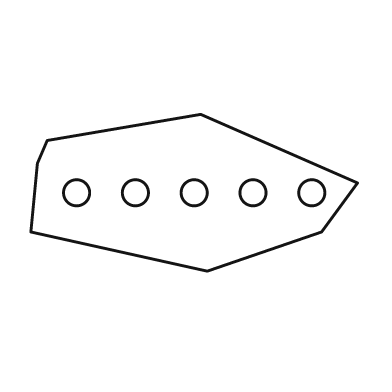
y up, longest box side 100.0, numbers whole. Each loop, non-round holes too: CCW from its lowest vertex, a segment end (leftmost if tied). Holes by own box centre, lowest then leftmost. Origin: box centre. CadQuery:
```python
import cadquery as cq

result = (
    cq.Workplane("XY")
    .moveTo(4.0, -24.0)
    .lineTo(39.0, -12.0)
    .lineTo(50.0, 3.0)
    .lineTo(2.0, 24.0)
    .lineTo(-45.0, 16.0)
    .lineTo(-48.0, 9.0)
    .lineTo(-50.0, -12.0)
    .close()
    .moveTo(-36.0, 0.0)
    .circle(4.0)
    .moveTo(-18.0, 0.0)
    .circle(4.0)
    .moveTo(0.0, 0.0)
    .circle(4.0)
    .moveTo(18.0, 0.0)
    .circle(4.0)
    .moveTo(36.0, 0.0)
    .circle(4.0)
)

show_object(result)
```